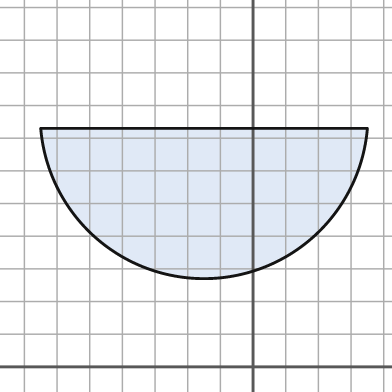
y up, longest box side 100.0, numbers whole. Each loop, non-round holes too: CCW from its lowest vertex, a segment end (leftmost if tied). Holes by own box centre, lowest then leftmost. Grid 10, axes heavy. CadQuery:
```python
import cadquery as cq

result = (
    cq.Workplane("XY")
    .moveTo(-65.0, 73.0)
    .threePointArc((-15.0, 27.0), (35.0, 73.0))
    .close()
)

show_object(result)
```